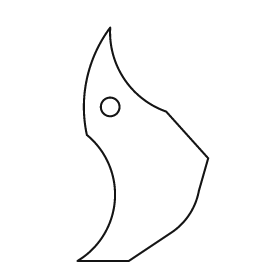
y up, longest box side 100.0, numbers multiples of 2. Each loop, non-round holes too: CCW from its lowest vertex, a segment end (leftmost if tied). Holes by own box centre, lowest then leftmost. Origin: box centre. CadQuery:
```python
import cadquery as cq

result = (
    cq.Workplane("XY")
    .moveTo(-28.0, -50.0)
    .lineTo(-6.0, -50.0)
    .lineTo(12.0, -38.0)
    .threePointArc((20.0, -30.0), (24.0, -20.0))
    .lineTo(28.0, -6.0)
    .lineTo(10.0, 14.0)
    .threePointArc((-8.0, 28.0), (-14.0, 50.0))
    .threePointArc((-24.0, 28.0), (-24.0, 4.0))
    .threePointArc((-12.0, -24.0), (-28.0, -50.0))
    .close()
    .moveTo(-14.0, 16.0)
    .circle(4.0)
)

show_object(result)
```